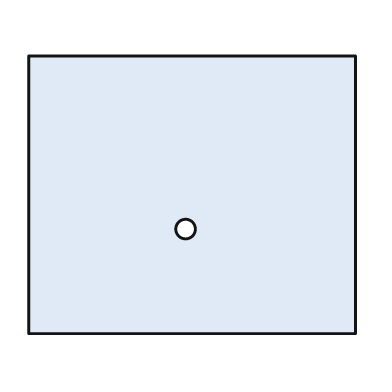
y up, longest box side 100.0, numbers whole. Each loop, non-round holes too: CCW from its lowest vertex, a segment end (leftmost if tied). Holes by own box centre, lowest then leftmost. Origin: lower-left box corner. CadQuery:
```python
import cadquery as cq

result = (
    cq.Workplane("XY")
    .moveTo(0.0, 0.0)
    .lineTo(100.0, 0.0)
    .lineTo(100.0, 85.0)
    .lineTo(0.0, 85.0)
    .close()
    .moveTo(48.0, 32.0)
    .circle(3.0)
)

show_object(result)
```